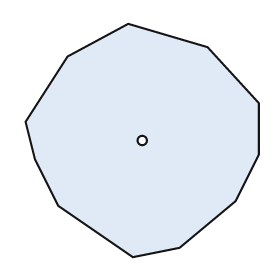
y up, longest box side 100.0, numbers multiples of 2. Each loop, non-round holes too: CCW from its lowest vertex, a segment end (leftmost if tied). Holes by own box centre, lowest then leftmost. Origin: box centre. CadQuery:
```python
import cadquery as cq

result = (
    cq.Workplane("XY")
    .moveTo(-4.0, -50.0)
    .lineTo(16.0, -46.0)
    .lineTo(40.0, -26.0)
    .lineTo(50.0, -6.0)
    .lineTo(50.0, 16.0)
    .lineTo(28.0, 40.0)
    .lineTo(-6.0, 50.0)
    .lineTo(-32.0, 36.0)
    .lineTo(-50.0, 8.0)
    .lineTo(-46.0, -8.0)
    .lineTo(-36.0, -28.0)
    .close()
    .moveTo(0.0, 0.0)
    .circle(2.0)
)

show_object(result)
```